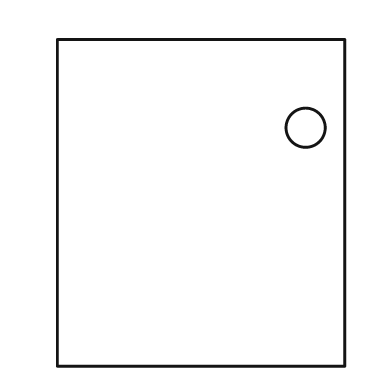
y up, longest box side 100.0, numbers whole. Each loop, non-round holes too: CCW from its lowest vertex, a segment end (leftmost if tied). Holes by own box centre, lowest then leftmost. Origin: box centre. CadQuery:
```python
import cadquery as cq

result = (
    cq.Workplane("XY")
    .moveTo(-44.0, -50.0)
    .lineTo(44.0, -50.0)
    .lineTo(44.0, 50.0)
    .lineTo(-44.0, 50.0)
    .close()
    .moveTo(32.0, 23.0)
    .circle(6.0)
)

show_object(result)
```